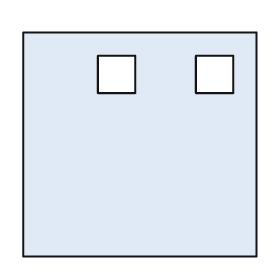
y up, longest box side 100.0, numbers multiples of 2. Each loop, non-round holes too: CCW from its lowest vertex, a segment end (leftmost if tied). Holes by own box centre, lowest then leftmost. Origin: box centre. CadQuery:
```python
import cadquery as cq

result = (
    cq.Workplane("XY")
    .moveTo(-50.0, -48.0)
    .lineTo(50.0, -48.0)
    .lineTo(50.0, 48.0)
    .lineTo(-50.0, 48.0)
    .close()
    .moveTo(-18.0, 22.0)
    .lineTo(-2.0, 22.0)
    .lineTo(-2.0, 38.0)
    .lineTo(-18.0, 38.0)
    .close()
    .moveTo(24.0, 22.0)
    .lineTo(40.0, 22.0)
    .lineTo(40.0, 38.0)
    .lineTo(24.0, 38.0)
    .close()
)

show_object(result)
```